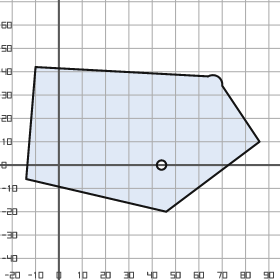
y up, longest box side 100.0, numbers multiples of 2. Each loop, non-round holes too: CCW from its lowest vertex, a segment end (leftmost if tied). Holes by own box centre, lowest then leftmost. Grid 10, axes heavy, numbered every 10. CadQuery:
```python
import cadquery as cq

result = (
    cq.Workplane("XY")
    .moveTo(46.0, -20.0)
    .lineTo(86.0, 10.0)
    .lineTo(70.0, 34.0)
    .threePointArc((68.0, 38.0), (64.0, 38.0))
    .lineTo(-10.0, 42.0)
    .lineTo(-14.0, -6.0)
    .close()
    .moveTo(44.0, 0.0)
    .circle(2.0)
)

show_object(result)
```